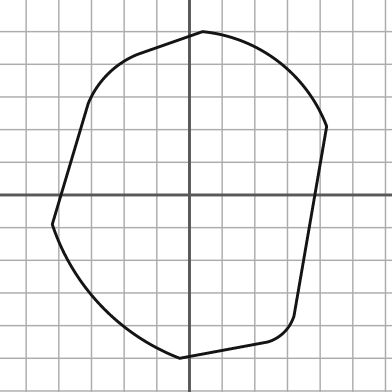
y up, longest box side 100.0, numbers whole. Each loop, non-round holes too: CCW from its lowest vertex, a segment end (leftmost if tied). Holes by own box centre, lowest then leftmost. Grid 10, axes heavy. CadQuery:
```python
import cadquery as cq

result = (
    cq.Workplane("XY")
    .moveTo(-3.0, -50.0)
    .lineTo(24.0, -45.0)
    .threePointArc((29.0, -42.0), (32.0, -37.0))
    .lineTo(42.0, 21.0)
    .threePointArc((27.0, 41.0), (4.0, 50.0))
    .lineTo(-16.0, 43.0)
    .threePointArc((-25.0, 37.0), (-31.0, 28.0))
    .lineTo(-42.0, -9.0)
    .threePointArc((-27.0, -34.0), (-3.0, -50.0))
    .close()
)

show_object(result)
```